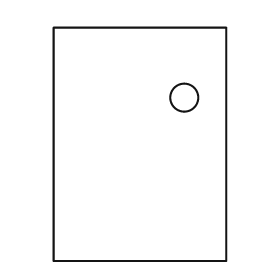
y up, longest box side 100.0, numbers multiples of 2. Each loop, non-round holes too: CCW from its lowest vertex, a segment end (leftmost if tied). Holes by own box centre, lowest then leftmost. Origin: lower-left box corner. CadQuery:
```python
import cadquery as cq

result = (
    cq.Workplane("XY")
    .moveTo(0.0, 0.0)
    .lineTo(74.0, 0.0)
    .lineTo(74.0, 100.0)
    .lineTo(0.0, 100.0)
    .close()
    .moveTo(56.0, 70.0)
    .circle(6.0)
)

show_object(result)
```